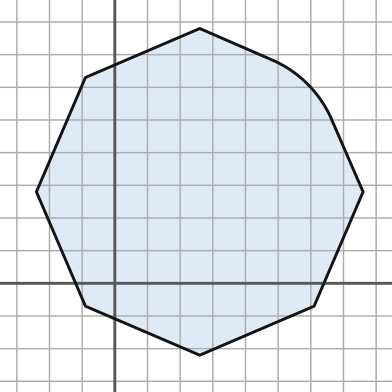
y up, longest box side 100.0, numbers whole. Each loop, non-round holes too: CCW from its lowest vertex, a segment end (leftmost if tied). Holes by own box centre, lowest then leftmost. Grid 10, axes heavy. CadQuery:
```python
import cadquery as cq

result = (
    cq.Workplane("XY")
    .moveTo(26.0, -22.0)
    .lineTo(61.0, -7.0)
    .lineTo(76.0, 28.0)
    .lineTo(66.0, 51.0)
    .threePointArc((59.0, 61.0), (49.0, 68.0))
    .lineTo(26.0, 78.0)
    .lineTo(-9.0, 63.0)
    .lineTo(-24.0, 28.0)
    .lineTo(-9.0, -7.0)
    .close()
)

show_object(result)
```